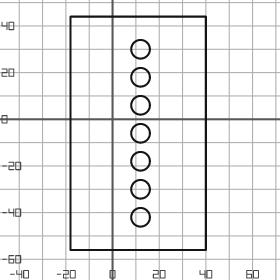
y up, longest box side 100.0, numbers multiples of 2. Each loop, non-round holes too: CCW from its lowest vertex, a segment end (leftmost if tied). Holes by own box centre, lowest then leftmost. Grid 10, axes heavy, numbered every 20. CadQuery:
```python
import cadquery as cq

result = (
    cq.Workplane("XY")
    .moveTo(-18.0, -56.0)
    .lineTo(40.0, -56.0)
    .lineTo(40.0, 44.0)
    .lineTo(-18.0, 44.0)
    .close()
    .moveTo(12.0, -42.0)
    .circle(4.0)
    .moveTo(12.0, -30.0)
    .circle(4.0)
    .moveTo(12.0, -18.0)
    .circle(4.0)
    .moveTo(12.0, -6.0)
    .circle(4.0)
    .moveTo(12.0, 6.0)
    .circle(4.0)
    .moveTo(12.0, 18.0)
    .circle(4.0)
    .moveTo(12.0, 30.0)
    .circle(4.0)
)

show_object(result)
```